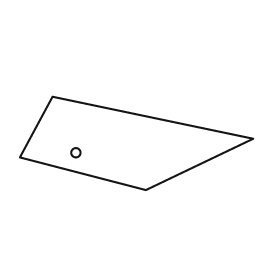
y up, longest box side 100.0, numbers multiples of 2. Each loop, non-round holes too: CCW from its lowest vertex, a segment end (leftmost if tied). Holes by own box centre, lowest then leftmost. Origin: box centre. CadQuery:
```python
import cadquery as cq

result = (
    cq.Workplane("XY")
    .moveTo(4.0, -20.0)
    .lineTo(50.0, 2.0)
    .lineTo(-36.0, 20.0)
    .lineTo(-50.0, -6.0)
    .close()
    .moveTo(-26.0, -4.0)
    .circle(2.0)
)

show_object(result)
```